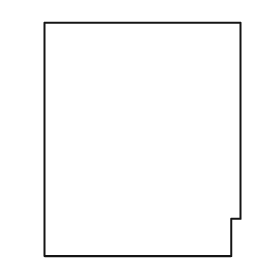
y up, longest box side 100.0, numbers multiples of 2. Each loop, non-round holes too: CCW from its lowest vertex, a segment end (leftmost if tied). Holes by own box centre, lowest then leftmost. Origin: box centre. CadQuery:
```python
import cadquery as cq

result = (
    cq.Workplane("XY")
    .moveTo(-42.0, -50.0)
    .lineTo(38.0, -50.0)
    .lineTo(38.0, -34.0)
    .lineTo(42.0, -34.0)
    .lineTo(42.0, 50.0)
    .lineTo(-42.0, 50.0)
    .close()
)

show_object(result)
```